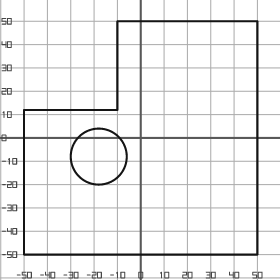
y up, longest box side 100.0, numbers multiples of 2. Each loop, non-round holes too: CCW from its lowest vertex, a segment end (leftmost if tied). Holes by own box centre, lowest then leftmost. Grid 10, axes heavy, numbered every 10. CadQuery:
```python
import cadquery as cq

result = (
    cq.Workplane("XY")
    .moveTo(-50.0, -50.0)
    .lineTo(50.0, -50.0)
    .lineTo(50.0, 50.0)
    .lineTo(-10.0, 50.0)
    .lineTo(-10.0, 12.0)
    .lineTo(-50.0, 12.0)
    .close()
    .moveTo(-18.0, -8.0)
    .circle(12.0)
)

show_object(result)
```